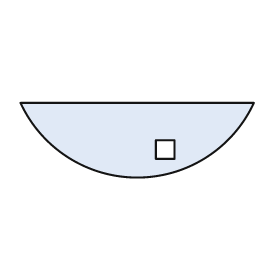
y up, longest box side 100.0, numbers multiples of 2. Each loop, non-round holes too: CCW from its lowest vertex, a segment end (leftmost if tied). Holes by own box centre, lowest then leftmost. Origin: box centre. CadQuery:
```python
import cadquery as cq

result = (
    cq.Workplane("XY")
    .moveTo(-50.0, 16.0)
    .threePointArc((0.0, -16.0), (50.0, 16.0))
    .close()
    .moveTo(8.0, -8.0)
    .lineTo(16.0, -8.0)
    .lineTo(16.0, 0.0)
    .lineTo(8.0, 0.0)
    .close()
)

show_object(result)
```